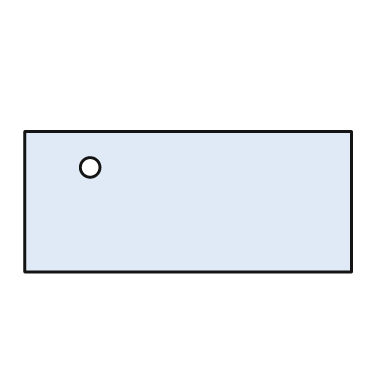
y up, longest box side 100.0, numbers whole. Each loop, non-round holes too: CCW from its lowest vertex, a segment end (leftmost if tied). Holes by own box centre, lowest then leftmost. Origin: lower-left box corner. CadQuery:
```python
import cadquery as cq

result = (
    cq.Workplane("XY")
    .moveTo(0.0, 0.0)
    .lineTo(100.0, 0.0)
    .lineTo(100.0, 43.0)
    .lineTo(0.0, 43.0)
    .close()
    .moveTo(20.0, 32.0)
    .circle(3.0)
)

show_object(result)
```